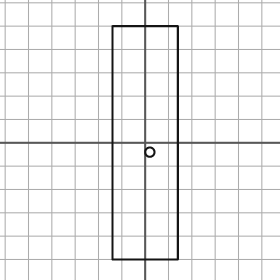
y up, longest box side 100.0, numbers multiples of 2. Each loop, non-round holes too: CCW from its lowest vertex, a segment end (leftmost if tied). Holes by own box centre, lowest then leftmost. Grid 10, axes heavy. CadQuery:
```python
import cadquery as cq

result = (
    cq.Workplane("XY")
    .moveTo(-14.0, -50.0)
    .lineTo(14.0, -50.0)
    .lineTo(14.0, 50.0)
    .lineTo(-14.0, 50.0)
    .close()
    .moveTo(2.0, -4.0)
    .circle(2.0)
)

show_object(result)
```